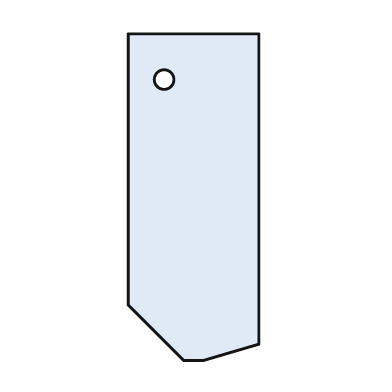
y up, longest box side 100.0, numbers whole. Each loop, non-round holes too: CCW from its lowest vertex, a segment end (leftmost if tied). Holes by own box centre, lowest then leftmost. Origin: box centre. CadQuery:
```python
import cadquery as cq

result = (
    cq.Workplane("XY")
    .moveTo(-3.0, -50.0)
    .lineTo(3.0, -50.0)
    .lineTo(20.0, -45.0)
    .lineTo(20.0, 50.0)
    .lineTo(-20.0, 50.0)
    .lineTo(-20.0, -33.0)
    .close()
    .moveTo(-9.0, 36.0)
    .circle(3.0)
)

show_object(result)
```